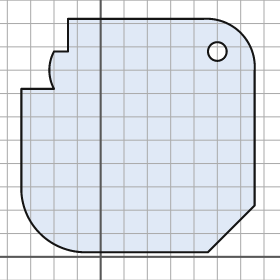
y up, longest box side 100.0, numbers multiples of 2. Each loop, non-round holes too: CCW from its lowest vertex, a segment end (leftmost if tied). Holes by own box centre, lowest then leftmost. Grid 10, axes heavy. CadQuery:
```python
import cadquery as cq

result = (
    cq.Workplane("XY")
    .moveTo(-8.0, 2.0)
    .lineTo(46.0, 2.0)
    .lineTo(66.0, 22.0)
    .lineTo(66.0, 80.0)
    .threePointArc((60.0, 96.0), (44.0, 102.0))
    .lineTo(-14.0, 102.0)
    .lineTo(-14.0, 88.0)
    .lineTo(-20.0, 88.0)
    .threePointArc((-22.0, 80.0), (-20.0, 72.0))
    .lineTo(-34.0, 72.0)
    .lineTo(-34.0, 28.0)
    .threePointArc((-26.0, 10.0), (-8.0, 2.0))
    .close()
    .moveTo(50.0, 88.0)
    .circle(4.0)
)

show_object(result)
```